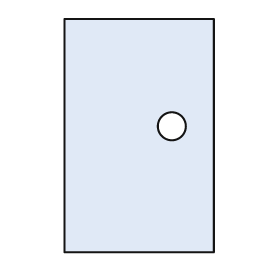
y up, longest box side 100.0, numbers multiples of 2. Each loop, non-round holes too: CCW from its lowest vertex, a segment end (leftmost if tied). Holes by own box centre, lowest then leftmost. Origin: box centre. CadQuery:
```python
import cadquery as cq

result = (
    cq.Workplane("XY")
    .moveTo(-32.0, -50.0)
    .lineTo(32.0, -50.0)
    .lineTo(32.0, 50.0)
    .lineTo(-32.0, 50.0)
    .close()
    .moveTo(14.0, 4.0)
    .circle(6.0)
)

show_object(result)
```